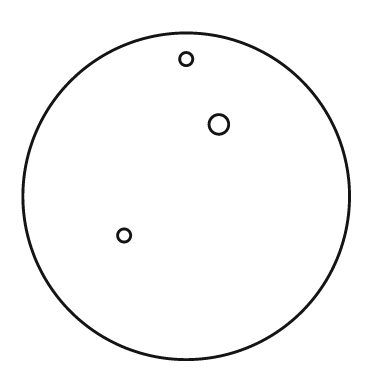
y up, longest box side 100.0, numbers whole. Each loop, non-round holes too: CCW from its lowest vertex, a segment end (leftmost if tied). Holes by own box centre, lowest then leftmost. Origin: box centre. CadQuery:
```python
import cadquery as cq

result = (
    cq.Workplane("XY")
    .moveTo(0.0, 0.0)
    .circle(50.0)
    .moveTo(-19.0, -12.0)
    .circle(2.0)
    .moveTo(10.0, 22.0)
    .circle(3.0)
    .moveTo(0.0, 42.0)
    .circle(2.0)
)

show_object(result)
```